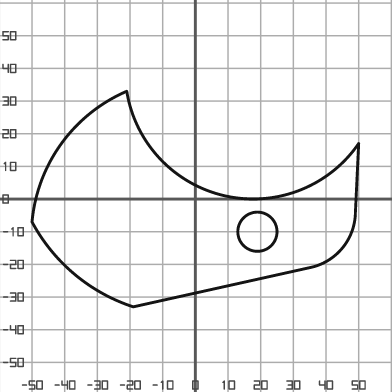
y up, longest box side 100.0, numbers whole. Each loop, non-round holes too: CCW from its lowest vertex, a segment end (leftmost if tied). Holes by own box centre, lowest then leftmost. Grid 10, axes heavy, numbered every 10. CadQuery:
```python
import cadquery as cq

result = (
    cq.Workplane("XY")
    .moveTo(-19.0, -33.0)
    .lineTo(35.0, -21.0)
    .threePointArc((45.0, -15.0), (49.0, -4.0))
    .lineTo(50.0, 17.0)
    .threePointArc((9.0, 1.0), (-21.0, 33.0))
    .threePointArc((-41.0, 17.0), (-50.0, -7.0))
    .threePointArc((-37.0, -23.0), (-19.0, -33.0))
    .close()
    .moveTo(19.0, -10.0)
    .circle(6.0)
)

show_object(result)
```